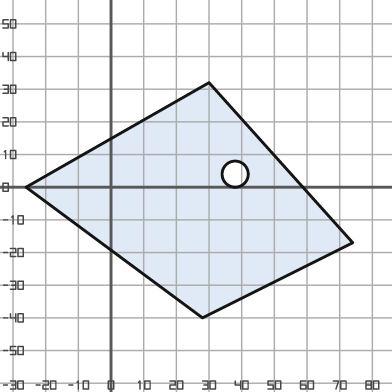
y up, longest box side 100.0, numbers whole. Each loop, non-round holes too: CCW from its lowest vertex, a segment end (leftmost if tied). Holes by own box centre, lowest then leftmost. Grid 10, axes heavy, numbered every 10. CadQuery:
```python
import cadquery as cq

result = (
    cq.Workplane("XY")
    .moveTo(28.0, -40.0)
    .lineTo(74.0, -17.0)
    .lineTo(30.0, 32.0)
    .lineTo(-26.0, 0.0)
    .close()
    .moveTo(38.0, 4.0)
    .circle(4.0)
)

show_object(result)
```